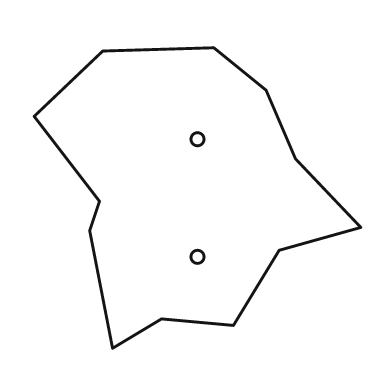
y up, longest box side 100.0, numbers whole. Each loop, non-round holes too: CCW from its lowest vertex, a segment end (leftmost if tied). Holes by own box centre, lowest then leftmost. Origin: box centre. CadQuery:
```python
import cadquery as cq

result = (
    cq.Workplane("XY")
    .moveTo(-26.0, -46.0)
    .lineTo(-11.0, -37.0)
    .lineTo(11.0, -39.0)
    .lineTo(25.0, -16.0)
    .lineTo(50.0, -9.0)
    .lineTo(30.0, 12.0)
    .lineTo(21.0, 33.0)
    .lineTo(5.0, 46.0)
    .lineTo(-29.0, 45.0)
    .lineTo(-50.0, 25.0)
    .lineTo(-30.0, -1.0)
    .lineTo(-33.0, -10.0)
    .close()
    .moveTo(0.0, -18.0)
    .circle(2.0)
    .moveTo(0.0, 18.0)
    .circle(2.0)
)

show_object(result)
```